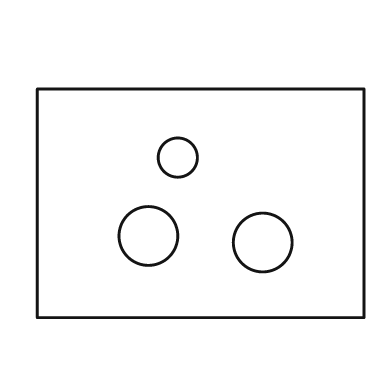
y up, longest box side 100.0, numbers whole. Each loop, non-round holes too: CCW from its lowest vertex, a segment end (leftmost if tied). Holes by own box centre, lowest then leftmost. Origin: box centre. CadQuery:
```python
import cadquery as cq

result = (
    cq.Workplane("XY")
    .moveTo(-50.0, -35.0)
    .lineTo(50.0, -35.0)
    .lineTo(50.0, 35.0)
    .lineTo(-50.0, 35.0)
    .close()
    .moveTo(19.0, -12.0)
    .circle(9.0)
    .moveTo(-16.0, -10.0)
    .circle(9.0)
    .moveTo(-7.0, 14.0)
    .circle(6.0)
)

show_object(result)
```